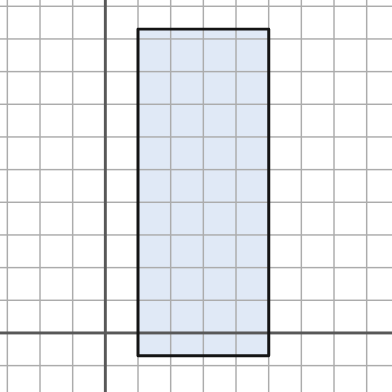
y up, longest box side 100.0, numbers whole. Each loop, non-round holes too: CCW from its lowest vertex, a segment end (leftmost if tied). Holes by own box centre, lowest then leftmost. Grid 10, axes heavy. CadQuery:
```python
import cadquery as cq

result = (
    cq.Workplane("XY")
    .moveTo(10.0, -7.0)
    .lineTo(50.0, -7.0)
    .lineTo(50.0, 93.0)
    .lineTo(10.0, 93.0)
    .close()
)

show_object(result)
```